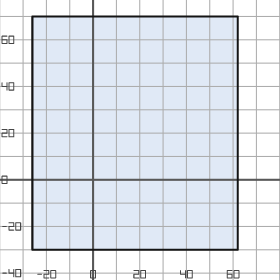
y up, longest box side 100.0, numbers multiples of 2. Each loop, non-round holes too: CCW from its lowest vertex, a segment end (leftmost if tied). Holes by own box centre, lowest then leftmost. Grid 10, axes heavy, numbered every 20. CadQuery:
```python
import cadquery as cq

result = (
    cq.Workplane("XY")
    .moveTo(-26.0, -30.0)
    .lineTo(62.0, -30.0)
    .lineTo(62.0, 70.0)
    .lineTo(-26.0, 70.0)
    .close()
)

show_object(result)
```